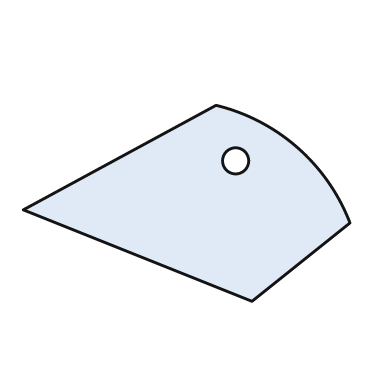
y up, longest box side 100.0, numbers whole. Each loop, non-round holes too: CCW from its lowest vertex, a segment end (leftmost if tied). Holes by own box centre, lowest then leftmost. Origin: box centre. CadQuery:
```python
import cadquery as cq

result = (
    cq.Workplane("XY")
    .moveTo(20.0, -30.0)
    .lineTo(50.0, -6.0)
    .threePointArc((34.0, 17.0), (9.0, 30.0))
    .lineTo(-50.0, -2.0)
    .close()
    .moveTo(15.0, 13.0)
    .circle(4.0)
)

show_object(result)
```